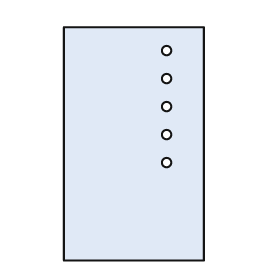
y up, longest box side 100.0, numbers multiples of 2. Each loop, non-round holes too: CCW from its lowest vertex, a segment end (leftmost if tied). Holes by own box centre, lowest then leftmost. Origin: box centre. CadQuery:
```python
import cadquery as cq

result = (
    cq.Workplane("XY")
    .moveTo(-30.0, -50.0)
    .lineTo(30.0, -50.0)
    .lineTo(30.0, 50.0)
    .lineTo(-30.0, 50.0)
    .close()
    .moveTo(14.0, -8.0)
    .circle(2.0)
    .moveTo(14.0, 4.0)
    .circle(2.0)
    .moveTo(14.0, 16.0)
    .circle(2.0)
    .moveTo(14.0, 28.0)
    .circle(2.0)
    .moveTo(14.0, 40.0)
    .circle(2.0)
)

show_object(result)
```